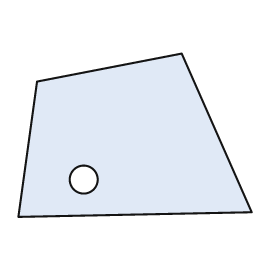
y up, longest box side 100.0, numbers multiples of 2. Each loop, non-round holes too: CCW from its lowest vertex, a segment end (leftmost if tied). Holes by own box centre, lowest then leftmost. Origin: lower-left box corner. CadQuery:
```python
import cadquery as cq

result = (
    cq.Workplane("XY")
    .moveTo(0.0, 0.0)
    .lineTo(100.0, 2.0)
    .lineTo(70.0, 70.0)
    .lineTo(8.0, 58.0)
    .close()
    .moveTo(28.0, 16.0)
    .circle(6.0)
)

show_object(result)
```